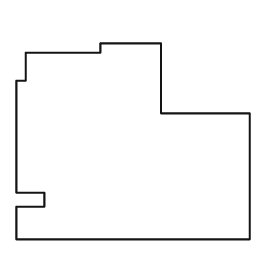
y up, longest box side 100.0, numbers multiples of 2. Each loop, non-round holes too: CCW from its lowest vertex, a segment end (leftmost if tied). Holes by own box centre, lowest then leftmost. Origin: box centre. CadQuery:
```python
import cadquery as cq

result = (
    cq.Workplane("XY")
    .moveTo(-50.0, -42.0)
    .lineTo(50.0, -42.0)
    .lineTo(50.0, 12.0)
    .lineTo(12.0, 12.0)
    .lineTo(12.0, 42.0)
    .lineTo(-14.0, 42.0)
    .lineTo(-14.0, 38.0)
    .lineTo(-46.0, 38.0)
    .lineTo(-46.0, 26.0)
    .lineTo(-50.0, 26.0)
    .lineTo(-50.0, -22.0)
    .lineTo(-38.0, -22.0)
    .lineTo(-38.0, -28.0)
    .lineTo(-50.0, -28.0)
    .close()
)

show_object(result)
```